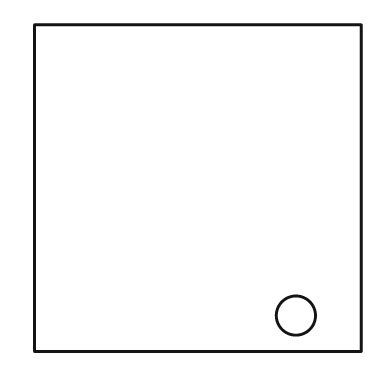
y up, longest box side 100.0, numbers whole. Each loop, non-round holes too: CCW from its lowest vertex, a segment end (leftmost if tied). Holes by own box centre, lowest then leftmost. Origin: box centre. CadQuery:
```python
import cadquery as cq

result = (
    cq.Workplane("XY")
    .moveTo(-50.0, -50.0)
    .lineTo(50.0, -50.0)
    .lineTo(50.0, 50.0)
    .lineTo(-50.0, 50.0)
    .close()
    .moveTo(30.0, -39.0)
    .circle(6.0)
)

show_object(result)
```